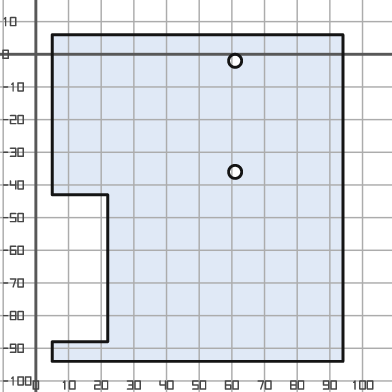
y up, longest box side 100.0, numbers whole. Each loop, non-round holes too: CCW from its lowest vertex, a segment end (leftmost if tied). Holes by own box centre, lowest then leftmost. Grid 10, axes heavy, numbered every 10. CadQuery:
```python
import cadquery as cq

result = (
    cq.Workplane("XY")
    .moveTo(5.0, -94.0)
    .lineTo(94.0, -94.0)
    .lineTo(94.0, 6.0)
    .lineTo(5.0, 6.0)
    .lineTo(5.0, -43.0)
    .lineTo(22.0, -43.0)
    .lineTo(22.0, -88.0)
    .lineTo(5.0, -88.0)
    .close()
    .moveTo(61.0, -36.0)
    .circle(2.0)
    .moveTo(61.0, -2.0)
    .circle(2.0)
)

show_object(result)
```